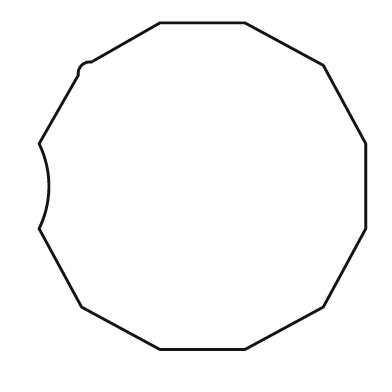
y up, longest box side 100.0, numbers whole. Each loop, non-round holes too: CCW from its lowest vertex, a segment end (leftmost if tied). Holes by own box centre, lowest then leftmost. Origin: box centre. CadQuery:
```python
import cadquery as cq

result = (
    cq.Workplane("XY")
    .moveTo(-13.0, -50.0)
    .lineTo(13.0, -50.0)
    .lineTo(37.0, -37.0)
    .lineTo(50.0, -13.0)
    .lineTo(50.0, 13.0)
    .lineTo(37.0, 37.0)
    .lineTo(13.0, 50.0)
    .lineTo(-13.0, 50.0)
    .lineTo(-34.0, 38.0)
    .threePointArc((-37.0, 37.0), (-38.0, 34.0))
    .lineTo(-50.0, 13.0)
    .threePointArc((-47.0, 0.0), (-50.0, -13.0))
    .lineTo(-37.0, -37.0)
    .close()
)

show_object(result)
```